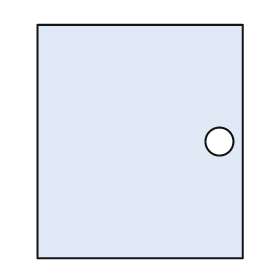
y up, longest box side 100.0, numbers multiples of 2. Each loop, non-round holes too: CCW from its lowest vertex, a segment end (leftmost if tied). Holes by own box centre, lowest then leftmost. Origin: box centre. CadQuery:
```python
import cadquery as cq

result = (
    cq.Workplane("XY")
    .moveTo(-44.0, -50.0)
    .lineTo(44.0, -50.0)
    .lineTo(44.0, 50.0)
    .lineTo(-44.0, 50.0)
    .close()
    .moveTo(34.0, 0.0)
    .circle(6.0)
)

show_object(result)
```